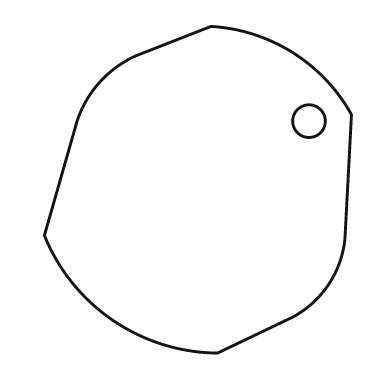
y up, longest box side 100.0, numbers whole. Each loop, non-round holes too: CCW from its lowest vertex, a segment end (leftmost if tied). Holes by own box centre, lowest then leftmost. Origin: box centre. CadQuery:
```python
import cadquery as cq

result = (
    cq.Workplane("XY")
    .moveTo(6.0, -50.0)
    .lineTo(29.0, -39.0)
    .threePointArc((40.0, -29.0), (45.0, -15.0))
    .lineTo(47.0, 23.0)
    .threePointArc((29.0, 42.0), (4.0, 50.0))
    .lineTo(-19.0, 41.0)
    .threePointArc((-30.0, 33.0), (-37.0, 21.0))
    .lineTo(-47.0, -14.0)
    .threePointArc((-26.0, -40.0), (6.0, -50.0))
    .close()
    .moveTo(34.0, 21.0)
    .circle(5.0)
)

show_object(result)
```